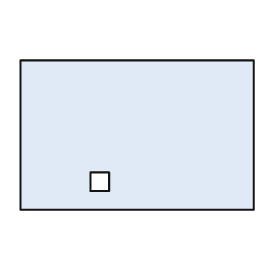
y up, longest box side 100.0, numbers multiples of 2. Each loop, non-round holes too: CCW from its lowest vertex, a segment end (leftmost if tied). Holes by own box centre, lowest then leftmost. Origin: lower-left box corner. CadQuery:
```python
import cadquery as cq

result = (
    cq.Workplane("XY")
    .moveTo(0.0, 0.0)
    .lineTo(100.0, 0.0)
    .lineTo(100.0, 64.0)
    .lineTo(0.0, 64.0)
    .close()
    .moveTo(30.0, 8.0)
    .lineTo(38.0, 8.0)
    .lineTo(38.0, 16.0)
    .lineTo(30.0, 16.0)
    .close()
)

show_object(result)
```